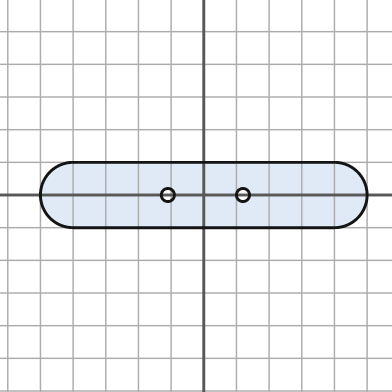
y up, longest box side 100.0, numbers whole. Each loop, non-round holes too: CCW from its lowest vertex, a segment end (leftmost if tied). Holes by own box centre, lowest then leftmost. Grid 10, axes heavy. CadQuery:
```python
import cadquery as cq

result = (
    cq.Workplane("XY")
    .moveTo(-40.0, -10.0)
    .lineTo(40.0, -10.0)
    .threePointArc((50.0, 0.0), (40.0, 10.0))
    .lineTo(-40.0, 10.0)
    .threePointArc((-50.0, 0.0), (-40.0, -10.0))
    .close()
    .moveTo(-11.0, 0.0)
    .circle(2.0)
    .moveTo(12.0, 0.0)
    .circle(2.0)
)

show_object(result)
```